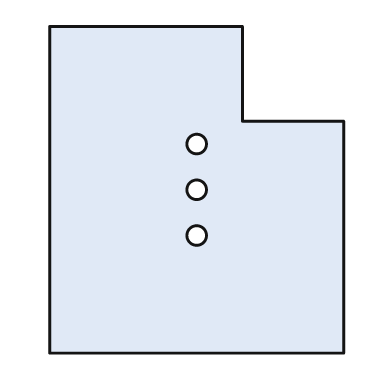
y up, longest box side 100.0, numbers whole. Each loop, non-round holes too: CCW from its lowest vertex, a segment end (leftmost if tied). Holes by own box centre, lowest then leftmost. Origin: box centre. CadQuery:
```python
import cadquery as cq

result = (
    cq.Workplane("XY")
    .moveTo(-45.0, -50.0)
    .lineTo(45.0, -50.0)
    .lineTo(45.0, 21.0)
    .lineTo(14.0, 21.0)
    .lineTo(14.0, 50.0)
    .lineTo(-45.0, 50.0)
    .close()
    .moveTo(0.0, -14.0)
    .circle(3.0)
    .moveTo(0.0, 0.0)
    .circle(3.0)
    .moveTo(0.0, 14.0)
    .circle(3.0)
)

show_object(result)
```